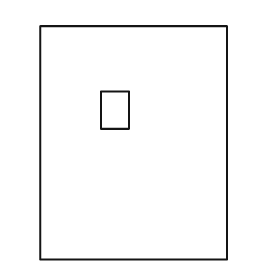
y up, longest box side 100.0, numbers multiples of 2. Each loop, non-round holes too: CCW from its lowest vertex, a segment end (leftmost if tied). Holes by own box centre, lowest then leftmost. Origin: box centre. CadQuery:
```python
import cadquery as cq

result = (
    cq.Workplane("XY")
    .moveTo(-40.0, -50.0)
    .lineTo(40.0, -50.0)
    .lineTo(40.0, 50.0)
    .lineTo(-40.0, 50.0)
    .close()
    .moveTo(-14.0, 6.0)
    .lineTo(-2.0, 6.0)
    .lineTo(-2.0, 22.0)
    .lineTo(-14.0, 22.0)
    .close()
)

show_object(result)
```